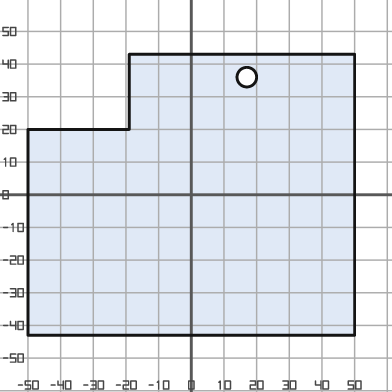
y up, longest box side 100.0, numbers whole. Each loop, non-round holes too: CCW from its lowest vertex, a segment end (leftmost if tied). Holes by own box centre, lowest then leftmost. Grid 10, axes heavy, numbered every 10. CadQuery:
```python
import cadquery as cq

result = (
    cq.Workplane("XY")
    .moveTo(-50.0, -43.0)
    .lineTo(50.0, -43.0)
    .lineTo(50.0, 43.0)
    .lineTo(-19.0, 43.0)
    .lineTo(-19.0, 20.0)
    .lineTo(-50.0, 20.0)
    .close()
    .moveTo(17.0, 36.0)
    .circle(3.0)
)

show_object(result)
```